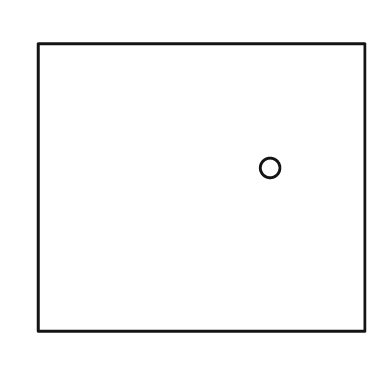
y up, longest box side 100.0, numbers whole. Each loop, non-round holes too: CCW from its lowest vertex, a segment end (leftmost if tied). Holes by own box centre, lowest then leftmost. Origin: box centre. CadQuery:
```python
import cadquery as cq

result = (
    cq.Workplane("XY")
    .moveTo(-50.0, -44.0)
    .lineTo(50.0, -44.0)
    .lineTo(50.0, 44.0)
    .lineTo(-50.0, 44.0)
    .close()
    .moveTo(21.0, 6.0)
    .circle(3.0)
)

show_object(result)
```